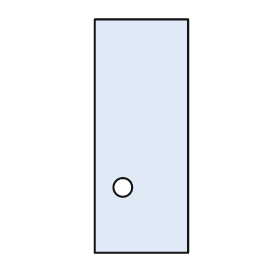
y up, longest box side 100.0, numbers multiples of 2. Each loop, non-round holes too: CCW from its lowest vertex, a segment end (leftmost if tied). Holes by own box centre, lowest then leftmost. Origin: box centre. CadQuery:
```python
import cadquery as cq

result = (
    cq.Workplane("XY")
    .moveTo(-20.0, -50.0)
    .lineTo(20.0, -50.0)
    .lineTo(20.0, 50.0)
    .lineTo(-20.0, 50.0)
    .close()
    .moveTo(-8.0, -22.0)
    .circle(4.0)
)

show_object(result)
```